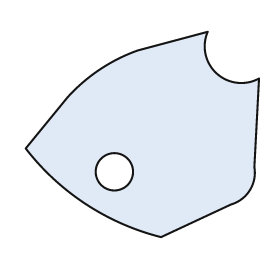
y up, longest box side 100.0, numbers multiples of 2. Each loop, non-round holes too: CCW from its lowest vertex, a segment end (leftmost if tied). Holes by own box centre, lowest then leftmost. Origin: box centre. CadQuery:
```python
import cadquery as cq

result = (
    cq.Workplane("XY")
    .moveTo(8.0, -44.0)
    .lineTo(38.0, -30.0)
    .threePointArc((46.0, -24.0), (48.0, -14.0))
    .lineTo(50.0, 24.0)
    .threePointArc((32.0, 26.0), (28.0, 44.0))
    .lineTo(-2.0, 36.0)
    .threePointArc((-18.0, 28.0), (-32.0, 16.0))
    .lineTo(-50.0, -6.0)
    .threePointArc((-24.0, -30.0), (8.0, -44.0))
    .close()
    .moveTo(-12.0, -16.0)
    .circle(8.0)
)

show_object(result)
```